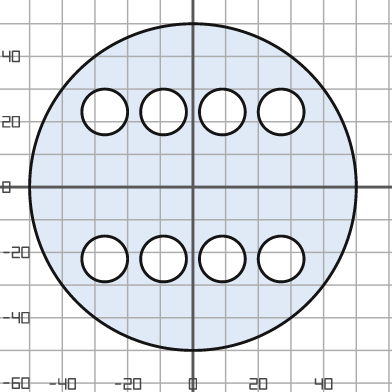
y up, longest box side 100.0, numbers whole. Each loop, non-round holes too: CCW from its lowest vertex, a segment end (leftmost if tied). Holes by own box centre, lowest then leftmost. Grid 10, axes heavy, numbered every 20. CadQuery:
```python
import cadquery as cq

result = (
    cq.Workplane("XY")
    .moveTo(0.0, 0.0)
    .circle(50.0)
    .moveTo(-27.0, -22.0)
    .circle(7.0)
    .moveTo(-9.0, -22.0)
    .circle(7.0)
    .moveTo(9.0, -22.0)
    .circle(7.0)
    .moveTo(27.0, -22.0)
    .circle(7.0)
    .moveTo(-27.0, 23.0)
    .circle(7.0)
    .moveTo(-9.0, 23.0)
    .circle(7.0)
    .moveTo(9.0, 23.0)
    .circle(7.0)
    .moveTo(27.0, 23.0)
    .circle(7.0)
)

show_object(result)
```